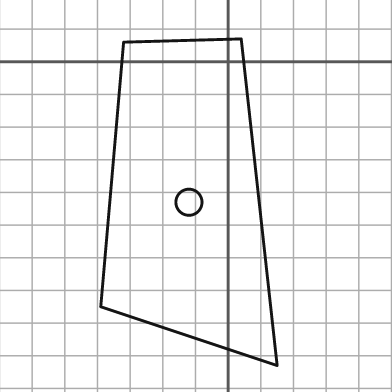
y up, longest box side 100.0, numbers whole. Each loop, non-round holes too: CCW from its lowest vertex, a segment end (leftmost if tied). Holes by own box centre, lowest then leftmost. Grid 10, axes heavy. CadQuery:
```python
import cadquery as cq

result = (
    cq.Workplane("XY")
    .moveTo(15.0, -93.0)
    .lineTo(4.0, 7.0)
    .lineTo(-32.0, 6.0)
    .lineTo(-39.0, -75.0)
    .close()
    .moveTo(-12.0, -43.0)
    .circle(4.0)
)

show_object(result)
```